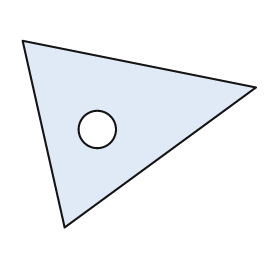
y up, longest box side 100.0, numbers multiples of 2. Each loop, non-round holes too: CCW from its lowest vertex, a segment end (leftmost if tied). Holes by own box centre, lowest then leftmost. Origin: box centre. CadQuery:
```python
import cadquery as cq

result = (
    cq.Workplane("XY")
    .moveTo(-32.0, -40.0)
    .lineTo(50.0, 20.0)
    .lineTo(-50.0, 40.0)
    .close()
    .moveTo(-18.0, 2.0)
    .circle(8.0)
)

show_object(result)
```